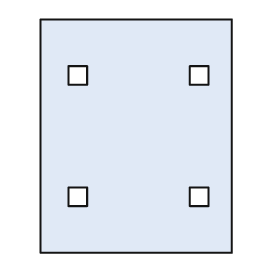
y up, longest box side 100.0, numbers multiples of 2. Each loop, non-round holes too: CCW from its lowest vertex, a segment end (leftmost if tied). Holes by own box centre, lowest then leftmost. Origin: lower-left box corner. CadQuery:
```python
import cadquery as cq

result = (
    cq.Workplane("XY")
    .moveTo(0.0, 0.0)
    .lineTo(82.0, 0.0)
    .lineTo(82.0, 100.0)
    .lineTo(0.0, 100.0)
    .close()
    .moveTo(12.0, 20.0)
    .lineTo(20.0, 20.0)
    .lineTo(20.0, 28.0)
    .lineTo(12.0, 28.0)
    .close()
    .moveTo(64.0, 20.0)
    .lineTo(72.0, 20.0)
    .lineTo(72.0, 28.0)
    .lineTo(64.0, 28.0)
    .close()
    .moveTo(12.0, 72.0)
    .lineTo(20.0, 72.0)
    .lineTo(20.0, 80.0)
    .lineTo(12.0, 80.0)
    .close()
    .moveTo(64.0, 72.0)
    .lineTo(72.0, 72.0)
    .lineTo(72.0, 80.0)
    .lineTo(64.0, 80.0)
    .close()
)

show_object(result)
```